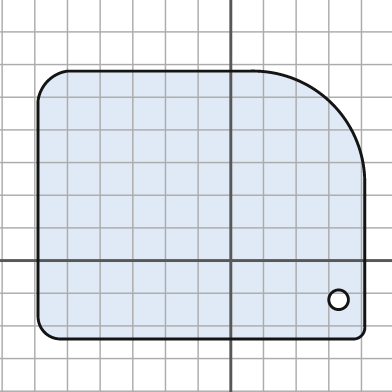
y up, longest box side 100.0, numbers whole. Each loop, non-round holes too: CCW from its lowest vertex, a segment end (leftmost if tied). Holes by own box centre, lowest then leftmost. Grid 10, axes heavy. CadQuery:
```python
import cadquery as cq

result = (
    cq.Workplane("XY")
    .moveTo(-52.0, -24.0)
    .lineTo(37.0, -24.0)
    .threePointArc((40.0, -23.0), (41.0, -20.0))
    .lineTo(41.0, 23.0)
    .threePointArc((31.0, 48.0), (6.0, 58.0))
    .lineTo(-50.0, 58.0)
    .threePointArc((-56.0, 55.0), (-59.0, 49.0))
    .lineTo(-59.0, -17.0)
    .threePointArc((-57.0, -22.0), (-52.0, -24.0))
    .close()
    .moveTo(33.0, -12.0)
    .circle(3.0)
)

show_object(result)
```